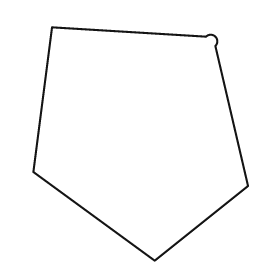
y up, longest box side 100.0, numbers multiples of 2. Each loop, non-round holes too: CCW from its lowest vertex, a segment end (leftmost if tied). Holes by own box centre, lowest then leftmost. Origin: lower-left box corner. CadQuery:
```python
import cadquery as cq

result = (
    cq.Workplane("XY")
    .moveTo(52.0, 0.0)
    .lineTo(92.0, 32.0)
    .lineTo(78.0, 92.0)
    .threePointArc((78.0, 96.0), (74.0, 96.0))
    .lineTo(8.0, 100.0)
    .lineTo(0.0, 38.0)
    .close()
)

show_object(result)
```